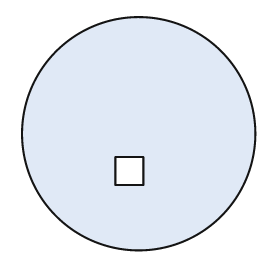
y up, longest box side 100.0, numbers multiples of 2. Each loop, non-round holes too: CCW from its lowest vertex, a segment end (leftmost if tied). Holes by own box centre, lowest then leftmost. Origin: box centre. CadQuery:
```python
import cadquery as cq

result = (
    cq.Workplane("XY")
    .moveTo(0.0, 0.0)
    .circle(50.0)
    .moveTo(-10.0, -22.0)
    .lineTo(2.0, -22.0)
    .lineTo(2.0, -10.0)
    .lineTo(-10.0, -10.0)
    .close()
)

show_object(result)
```